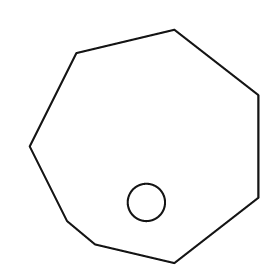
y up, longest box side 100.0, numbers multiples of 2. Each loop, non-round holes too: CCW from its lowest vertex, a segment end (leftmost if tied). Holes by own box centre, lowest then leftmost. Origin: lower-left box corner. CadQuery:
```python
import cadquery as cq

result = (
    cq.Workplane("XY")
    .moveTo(62.0, 0.0)
    .lineTo(98.0, 28.0)
    .lineTo(98.0, 72.0)
    .lineTo(62.0, 100.0)
    .lineTo(20.0, 90.0)
    .lineTo(0.0, 50.0)
    .lineTo(16.0, 18.0)
    .lineTo(28.0, 8.0)
    .close()
    .moveTo(50.0, 26.0)
    .circle(8.0)
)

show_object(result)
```